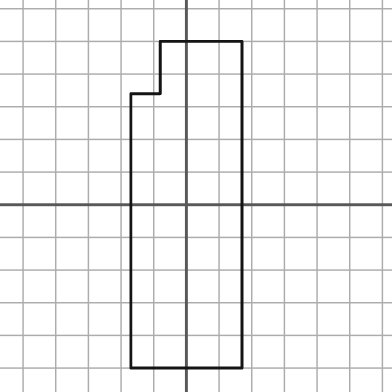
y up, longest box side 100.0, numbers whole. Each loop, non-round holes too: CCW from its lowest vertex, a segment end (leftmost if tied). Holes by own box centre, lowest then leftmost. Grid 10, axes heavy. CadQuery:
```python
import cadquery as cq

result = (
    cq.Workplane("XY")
    .moveTo(-17.0, -50.0)
    .lineTo(17.0, -50.0)
    .lineTo(17.0, 50.0)
    .lineTo(-8.0, 50.0)
    .lineTo(-8.0, 34.0)
    .lineTo(-17.0, 34.0)
    .close()
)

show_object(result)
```